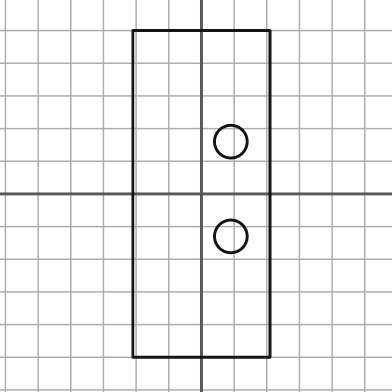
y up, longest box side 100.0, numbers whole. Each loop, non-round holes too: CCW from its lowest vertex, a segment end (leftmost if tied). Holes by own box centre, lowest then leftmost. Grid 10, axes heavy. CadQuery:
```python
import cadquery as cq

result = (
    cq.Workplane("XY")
    .moveTo(-21.0, -50.0)
    .lineTo(21.0, -50.0)
    .lineTo(21.0, 50.0)
    .lineTo(-21.0, 50.0)
    .close()
    .moveTo(9.0, -13.0)
    .circle(5.0)
    .moveTo(9.0, 16.0)
    .circle(5.0)
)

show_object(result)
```